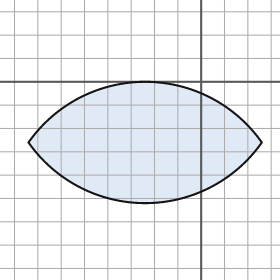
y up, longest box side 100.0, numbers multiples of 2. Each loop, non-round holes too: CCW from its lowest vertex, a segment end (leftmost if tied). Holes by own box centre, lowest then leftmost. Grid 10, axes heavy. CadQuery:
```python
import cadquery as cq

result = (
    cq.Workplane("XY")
    .moveTo(-74.0, -26.0)
    .threePointArc((-24.0, -52.0), (26.0, -26.0))
    .threePointArc((-24.0, 0.0), (-74.0, -26.0))
    .close()
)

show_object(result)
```